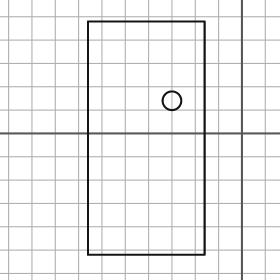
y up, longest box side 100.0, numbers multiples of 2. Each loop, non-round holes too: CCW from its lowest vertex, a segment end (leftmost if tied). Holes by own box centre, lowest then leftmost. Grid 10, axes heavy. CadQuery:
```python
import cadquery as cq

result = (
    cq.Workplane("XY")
    .moveTo(-66.0, -52.0)
    .lineTo(-16.0, -52.0)
    .lineTo(-16.0, 48.0)
    .lineTo(-66.0, 48.0)
    .close()
    .moveTo(-30.0, 14.0)
    .circle(4.0)
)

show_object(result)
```